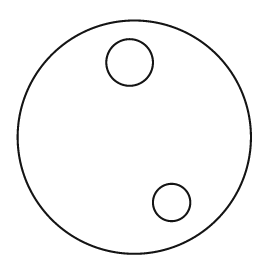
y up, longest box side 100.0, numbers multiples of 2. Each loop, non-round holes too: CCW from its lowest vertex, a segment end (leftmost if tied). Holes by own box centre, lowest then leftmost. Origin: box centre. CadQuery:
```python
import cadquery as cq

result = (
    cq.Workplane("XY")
    .moveTo(0.0, 0.0)
    .circle(50.0)
    .moveTo(16.0, -28.0)
    .circle(8.0)
    .moveTo(-2.0, 32.0)
    .circle(10.0)
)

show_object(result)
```